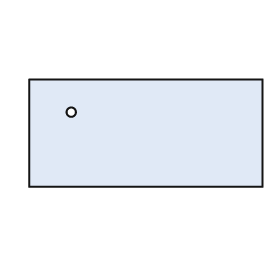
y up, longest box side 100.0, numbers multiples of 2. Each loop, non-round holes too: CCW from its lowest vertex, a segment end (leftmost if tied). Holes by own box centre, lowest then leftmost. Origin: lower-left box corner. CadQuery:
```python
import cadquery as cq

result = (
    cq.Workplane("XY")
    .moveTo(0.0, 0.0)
    .lineTo(100.0, 0.0)
    .lineTo(100.0, 46.0)
    .lineTo(0.0, 46.0)
    .close()
    .moveTo(18.0, 32.0)
    .circle(2.0)
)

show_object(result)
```